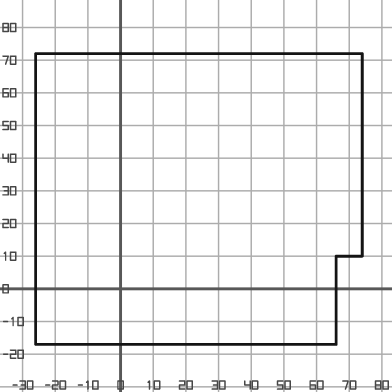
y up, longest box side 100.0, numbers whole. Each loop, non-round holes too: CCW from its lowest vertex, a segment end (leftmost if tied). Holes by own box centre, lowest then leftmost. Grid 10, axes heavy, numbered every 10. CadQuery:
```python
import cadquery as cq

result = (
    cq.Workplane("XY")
    .moveTo(-26.0, -17.0)
    .lineTo(66.0, -17.0)
    .lineTo(66.0, 10.0)
    .lineTo(74.0, 10.0)
    .lineTo(74.0, 72.0)
    .lineTo(-26.0, 72.0)
    .close()
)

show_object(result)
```